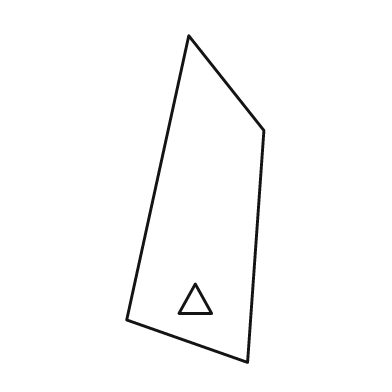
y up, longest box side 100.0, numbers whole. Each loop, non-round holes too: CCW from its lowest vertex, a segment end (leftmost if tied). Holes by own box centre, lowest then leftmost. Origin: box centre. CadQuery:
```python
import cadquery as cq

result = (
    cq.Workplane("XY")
    .moveTo(16.0, -50.0)
    .lineTo(21.0, 21.0)
    .lineTo(-2.0, 50.0)
    .lineTo(-21.0, -37.0)
    .close()
    .moveTo(-5.0, -35.0)
    .lineTo(5.0, -35.0)
    .lineTo(0.0, -26.0)
    .close()
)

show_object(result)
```